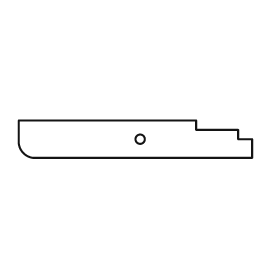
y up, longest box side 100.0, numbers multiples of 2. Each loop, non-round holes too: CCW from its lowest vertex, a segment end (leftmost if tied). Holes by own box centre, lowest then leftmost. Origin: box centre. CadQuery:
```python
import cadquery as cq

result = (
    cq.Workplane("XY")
    .moveTo(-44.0, -8.0)
    .lineTo(50.0, -8.0)
    .lineTo(50.0, 0.0)
    .lineTo(44.0, 0.0)
    .lineTo(44.0, 4.0)
    .lineTo(26.0, 4.0)
    .lineTo(26.0, 8.0)
    .lineTo(-50.0, 8.0)
    .lineTo(-50.0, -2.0)
    .threePointArc((-48.0, -6.0), (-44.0, -8.0))
    .close()
    .moveTo(2.0, 0.0)
    .circle(2.0)
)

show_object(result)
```